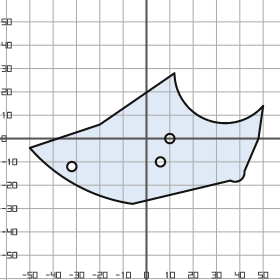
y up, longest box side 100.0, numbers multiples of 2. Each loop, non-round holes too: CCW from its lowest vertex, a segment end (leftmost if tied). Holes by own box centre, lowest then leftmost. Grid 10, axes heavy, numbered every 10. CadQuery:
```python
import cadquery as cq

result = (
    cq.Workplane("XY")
    .moveTo(-6.0, -28.0)
    .lineTo(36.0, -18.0)
    .threePointArc((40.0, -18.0), (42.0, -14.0))
    .lineTo(48.0, 0.0)
    .lineTo(50.0, 14.0)
    .threePointArc((26.0, 8.0), (12.0, 28.0))
    .lineTo(-20.0, 6.0)
    .lineTo(-50.0, -4.0)
    .threePointArc((-30.0, -20.0), (-6.0, -28.0))
    .close()
    .moveTo(-32.0, -12.0)
    .circle(2.0)
    .moveTo(6.0, -10.0)
    .circle(2.0)
    .moveTo(10.0, 0.0)
    .circle(2.0)
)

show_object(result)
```